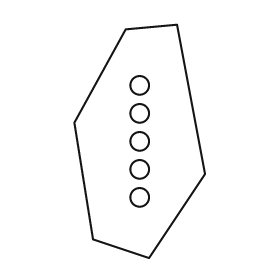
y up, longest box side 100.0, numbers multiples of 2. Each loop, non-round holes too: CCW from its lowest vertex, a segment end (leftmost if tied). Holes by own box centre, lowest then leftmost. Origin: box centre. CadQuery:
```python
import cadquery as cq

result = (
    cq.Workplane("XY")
    .moveTo(4.0, -50.0)
    .lineTo(28.0, -14.0)
    .lineTo(16.0, 50.0)
    .lineTo(-6.0, 48.0)
    .lineTo(-28.0, 8.0)
    .lineTo(-20.0, -42.0)
    .close()
    .moveTo(0.0, -24.0)
    .circle(4.0)
    .moveTo(0.0, -12.0)
    .circle(4.0)
    .moveTo(0.0, 0.0)
    .circle(4.0)
    .moveTo(0.0, 12.0)
    .circle(4.0)
    .moveTo(0.0, 24.0)
    .circle(4.0)
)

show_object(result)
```